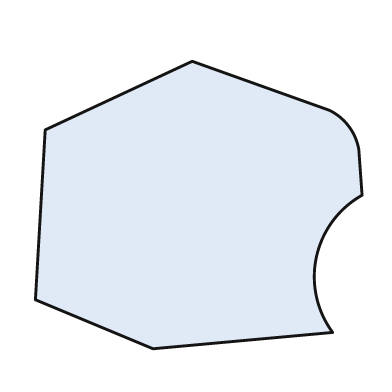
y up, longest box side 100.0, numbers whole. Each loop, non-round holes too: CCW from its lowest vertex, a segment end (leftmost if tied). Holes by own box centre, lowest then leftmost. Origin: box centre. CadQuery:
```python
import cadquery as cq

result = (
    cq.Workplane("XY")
    .moveTo(-14.0, -44.0)
    .lineTo(41.0, -39.0)
    .threePointArc((36.0, -16.0), (50.0, 3.0))
    .lineTo(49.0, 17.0)
    .threePointArc((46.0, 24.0), (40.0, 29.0))
    .lineTo(-2.0, 44.0)
    .lineTo(-47.0, 23.0)
    .lineTo(-50.0, -29.0)
    .close()
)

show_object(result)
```